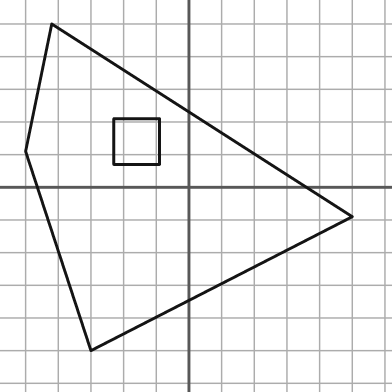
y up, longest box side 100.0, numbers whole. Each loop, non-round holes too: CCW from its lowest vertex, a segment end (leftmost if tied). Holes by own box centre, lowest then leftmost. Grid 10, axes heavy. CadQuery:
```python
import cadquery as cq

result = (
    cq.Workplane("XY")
    .moveTo(-30.0, -50.0)
    .lineTo(50.0, -9.0)
    .lineTo(-42.0, 50.0)
    .lineTo(-50.0, 11.0)
    .close()
    .moveTo(-23.0, 7.0)
    .lineTo(-9.0, 7.0)
    .lineTo(-9.0, 21.0)
    .lineTo(-23.0, 21.0)
    .close()
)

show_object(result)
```